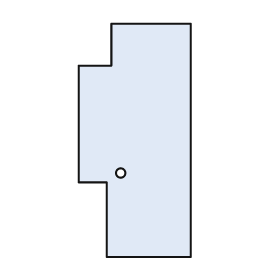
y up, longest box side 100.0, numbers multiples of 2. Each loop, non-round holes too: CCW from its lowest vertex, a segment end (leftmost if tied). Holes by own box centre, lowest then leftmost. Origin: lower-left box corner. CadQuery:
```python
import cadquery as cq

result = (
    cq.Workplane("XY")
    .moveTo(12.0, 0.0)
    .lineTo(48.0, 0.0)
    .lineTo(48.0, 100.0)
    .lineTo(14.0, 100.0)
    .lineTo(14.0, 82.0)
    .lineTo(0.0, 82.0)
    .lineTo(0.0, 32.0)
    .lineTo(12.0, 32.0)
    .close()
    .moveTo(18.0, 36.0)
    .circle(2.0)
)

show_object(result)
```